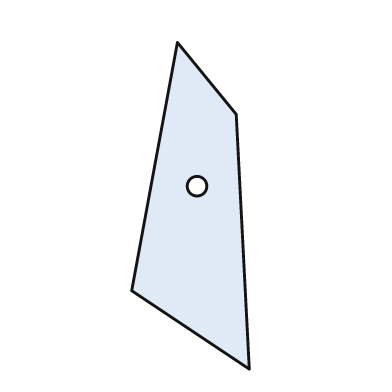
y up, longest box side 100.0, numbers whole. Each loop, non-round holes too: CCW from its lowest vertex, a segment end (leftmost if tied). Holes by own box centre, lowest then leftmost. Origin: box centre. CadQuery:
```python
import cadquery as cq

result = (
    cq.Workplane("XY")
    .moveTo(18.0, -50.0)
    .lineTo(14.0, 28.0)
    .lineTo(-4.0, 50.0)
    .lineTo(-18.0, -26.0)
    .close()
    .moveTo(2.0, 6.0)
    .circle(3.0)
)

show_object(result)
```